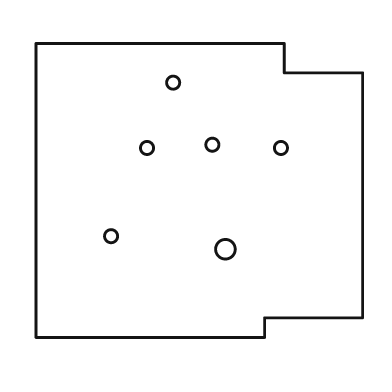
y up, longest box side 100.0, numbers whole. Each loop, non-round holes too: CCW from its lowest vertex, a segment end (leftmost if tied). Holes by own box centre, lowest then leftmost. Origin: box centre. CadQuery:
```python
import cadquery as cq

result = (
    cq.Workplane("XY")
    .moveTo(-50.0, -45.0)
    .lineTo(20.0, -45.0)
    .lineTo(20.0, -39.0)
    .lineTo(50.0, -39.0)
    .lineTo(50.0, 36.0)
    .lineTo(26.0, 36.0)
    .lineTo(26.0, 45.0)
    .lineTo(-50.0, 45.0)
    .close()
    .moveTo(8.0, -18.0)
    .circle(3.0)
    .moveTo(-27.0, -14.0)
    .circle(2.0)
    .moveTo(-16.0, 13.0)
    .circle(2.0)
    .moveTo(25.0, 13.0)
    .circle(2.0)
    .moveTo(4.0, 14.0)
    .circle(2.0)
    .moveTo(-8.0, 33.0)
    .circle(2.0)
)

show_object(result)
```